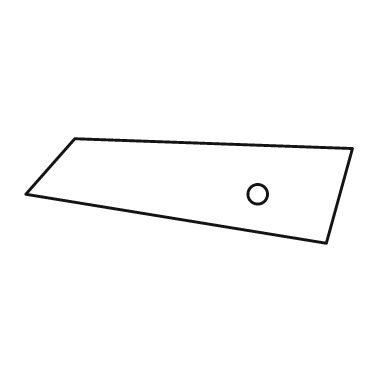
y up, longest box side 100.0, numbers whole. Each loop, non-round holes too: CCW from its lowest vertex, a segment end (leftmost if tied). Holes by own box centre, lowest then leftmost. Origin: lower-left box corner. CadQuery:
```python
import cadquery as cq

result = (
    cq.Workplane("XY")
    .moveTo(92.0, 0.0)
    .lineTo(100.0, 29.0)
    .lineTo(15.0, 32.0)
    .lineTo(0.0, 15.0)
    .close()
    .moveTo(71.0, 15.0)
    .circle(3.0)
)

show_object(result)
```